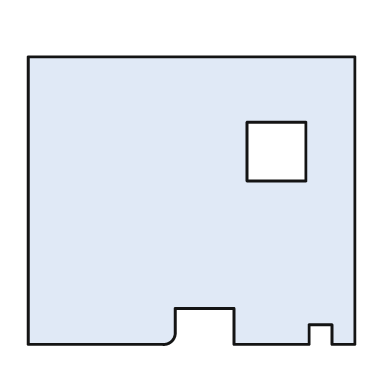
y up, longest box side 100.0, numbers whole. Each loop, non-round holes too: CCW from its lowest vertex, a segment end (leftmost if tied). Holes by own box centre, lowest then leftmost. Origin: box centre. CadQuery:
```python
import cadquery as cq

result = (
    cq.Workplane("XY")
    .moveTo(-50.0, -44.0)
    .lineTo(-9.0, -44.0)
    .threePointArc((-6.0, -43.0), (-5.0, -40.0))
    .lineTo(-5.0, -33.0)
    .lineTo(13.0, -33.0)
    .lineTo(13.0, -44.0)
    .lineTo(36.0, -44.0)
    .lineTo(36.0, -38.0)
    .lineTo(43.0, -38.0)
    .lineTo(43.0, -44.0)
    .lineTo(50.0, -44.0)
    .lineTo(50.0, 44.0)
    .lineTo(-50.0, 44.0)
    .close()
    .moveTo(17.0, 6.0)
    .lineTo(35.0, 6.0)
    .lineTo(35.0, 24.0)
    .lineTo(17.0, 24.0)
    .close()
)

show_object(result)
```